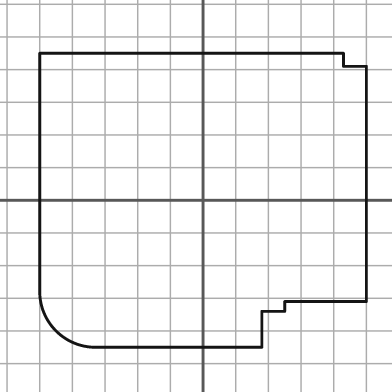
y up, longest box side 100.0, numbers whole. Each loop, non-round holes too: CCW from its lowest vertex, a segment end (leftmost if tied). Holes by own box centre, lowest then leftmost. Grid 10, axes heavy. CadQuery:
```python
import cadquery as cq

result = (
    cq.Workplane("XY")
    .moveTo(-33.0, -45.0)
    .lineTo(18.0, -45.0)
    .lineTo(18.0, -34.0)
    .lineTo(25.0, -34.0)
    .lineTo(25.0, -31.0)
    .lineTo(50.0, -31.0)
    .lineTo(50.0, 41.0)
    .lineTo(43.0, 41.0)
    .lineTo(43.0, 45.0)
    .lineTo(-50.0, 45.0)
    .lineTo(-50.0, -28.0)
    .threePointArc((-45.0, -40.0), (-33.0, -45.0))
    .close()
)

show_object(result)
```